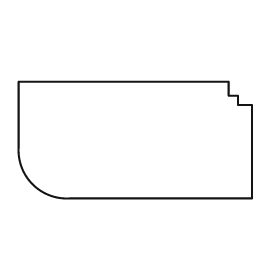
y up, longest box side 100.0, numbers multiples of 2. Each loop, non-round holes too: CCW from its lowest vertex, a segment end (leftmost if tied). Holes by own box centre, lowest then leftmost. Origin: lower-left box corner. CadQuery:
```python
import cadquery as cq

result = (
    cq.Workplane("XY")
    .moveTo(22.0, 0.0)
    .lineTo(100.0, 0.0)
    .lineTo(100.0, 40.0)
    .lineTo(94.0, 40.0)
    .lineTo(94.0, 44.0)
    .lineTo(90.0, 44.0)
    .lineTo(90.0, 50.0)
    .lineTo(0.0, 50.0)
    .lineTo(0.0, 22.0)
    .threePointArc((6.0, 6.0), (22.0, 0.0))
    .close()
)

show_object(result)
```